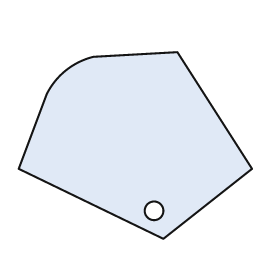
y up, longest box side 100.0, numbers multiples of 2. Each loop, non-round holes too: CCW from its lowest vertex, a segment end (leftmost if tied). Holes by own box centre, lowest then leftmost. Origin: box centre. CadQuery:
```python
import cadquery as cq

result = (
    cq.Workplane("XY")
    .moveTo(12.0, -40.0)
    .lineTo(50.0, -10.0)
    .lineTo(18.0, 40.0)
    .lineTo(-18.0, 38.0)
    .threePointArc((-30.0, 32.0), (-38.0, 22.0))
    .lineTo(-50.0, -10.0)
    .close()
    .moveTo(8.0, -28.0)
    .circle(4.0)
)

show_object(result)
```